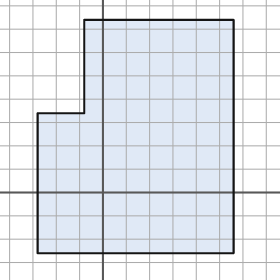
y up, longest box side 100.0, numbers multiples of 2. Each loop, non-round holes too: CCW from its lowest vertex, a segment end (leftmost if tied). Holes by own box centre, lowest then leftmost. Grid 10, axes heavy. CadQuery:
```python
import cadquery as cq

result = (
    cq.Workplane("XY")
    .moveTo(-28.0, -26.0)
    .lineTo(56.0, -26.0)
    .lineTo(56.0, 74.0)
    .lineTo(-8.0, 74.0)
    .lineTo(-8.0, 34.0)
    .lineTo(-28.0, 34.0)
    .close()
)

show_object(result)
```